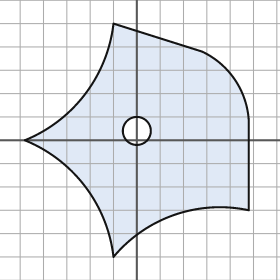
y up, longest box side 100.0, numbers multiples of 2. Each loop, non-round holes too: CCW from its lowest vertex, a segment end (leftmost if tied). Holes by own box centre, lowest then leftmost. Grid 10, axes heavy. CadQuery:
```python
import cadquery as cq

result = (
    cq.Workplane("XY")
    .moveTo(-10.0, -50.0)
    .threePointArc((16.0, -32.0), (48.0, -30.0))
    .lineTo(48.0, 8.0)
    .threePointArc((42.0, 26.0), (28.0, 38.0))
    .lineTo(-10.0, 50.0)
    .threePointArc((-22.0, 20.0), (-48.0, 0.0))
    .threePointArc((-22.0, -20.0), (-10.0, -50.0))
    .close()
    .moveTo(0.0, 4.0)
    .circle(6.0)
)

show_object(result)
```